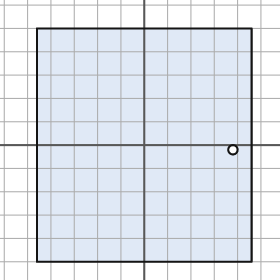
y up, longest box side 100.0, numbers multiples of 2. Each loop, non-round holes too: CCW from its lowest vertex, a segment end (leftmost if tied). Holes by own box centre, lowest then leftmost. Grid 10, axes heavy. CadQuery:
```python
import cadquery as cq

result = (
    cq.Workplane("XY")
    .moveTo(-46.0, -50.0)
    .lineTo(46.0, -50.0)
    .lineTo(46.0, 50.0)
    .lineTo(-46.0, 50.0)
    .close()
    .moveTo(38.0, -2.0)
    .circle(2.0)
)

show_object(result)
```